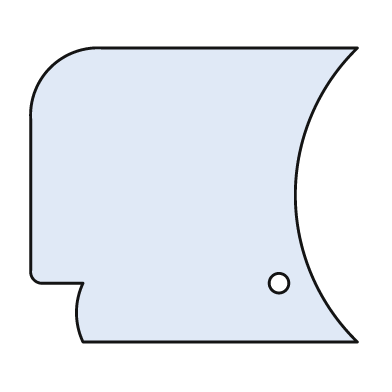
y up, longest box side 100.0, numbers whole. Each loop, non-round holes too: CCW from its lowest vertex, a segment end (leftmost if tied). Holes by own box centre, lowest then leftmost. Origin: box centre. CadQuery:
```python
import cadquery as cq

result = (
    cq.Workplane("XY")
    .moveTo(-34.0, -45.0)
    .lineTo(50.0, -45.0)
    .threePointArc((31.0, 0.0), (50.0, 45.0))
    .lineTo(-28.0, 45.0)
    .threePointArc((-44.0, 39.0), (-50.0, 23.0))
    .lineTo(-50.0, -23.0)
    .threePointArc((-49.0, -26.0), (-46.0, -27.0))
    .lineTo(-34.0, -27.0)
    .threePointArc((-36.0, -36.0), (-34.0, -45.0))
    .close()
    .moveTo(26.0, -27.0)
    .circle(3.0)
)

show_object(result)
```